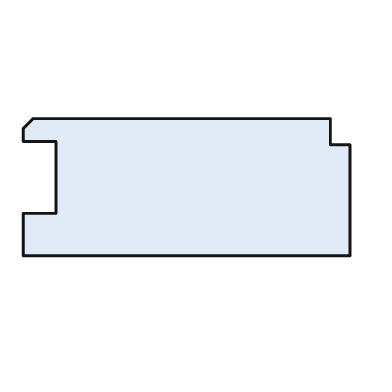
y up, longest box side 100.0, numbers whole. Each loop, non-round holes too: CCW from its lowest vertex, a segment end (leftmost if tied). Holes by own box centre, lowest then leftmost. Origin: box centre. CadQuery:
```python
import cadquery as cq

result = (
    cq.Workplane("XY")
    .moveTo(-50.0, -21.0)
    .lineTo(50.0, -21.0)
    .lineTo(50.0, 13.0)
    .lineTo(44.0, 13.0)
    .lineTo(44.0, 21.0)
    .lineTo(-47.0, 21.0)
    .lineTo(-50.0, 18.0)
    .lineTo(-50.0, 14.0)
    .lineTo(-40.0, 14.0)
    .lineTo(-40.0, -8.0)
    .lineTo(-50.0, -8.0)
    .close()
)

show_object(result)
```